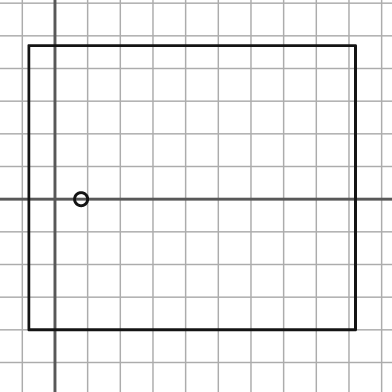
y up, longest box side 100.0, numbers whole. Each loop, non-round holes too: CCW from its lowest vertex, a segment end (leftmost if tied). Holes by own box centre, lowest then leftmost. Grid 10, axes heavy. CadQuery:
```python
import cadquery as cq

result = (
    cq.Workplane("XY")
    .moveTo(-8.0, -40.0)
    .lineTo(92.0, -40.0)
    .lineTo(92.0, 47.0)
    .lineTo(-8.0, 47.0)
    .close()
    .moveTo(8.0, 0.0)
    .circle(2.0)
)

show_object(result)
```